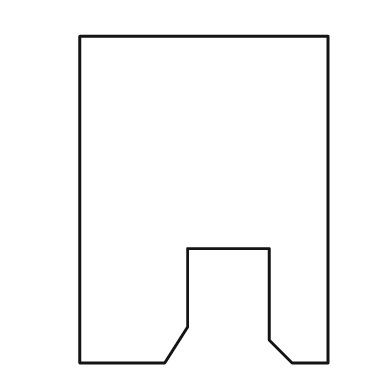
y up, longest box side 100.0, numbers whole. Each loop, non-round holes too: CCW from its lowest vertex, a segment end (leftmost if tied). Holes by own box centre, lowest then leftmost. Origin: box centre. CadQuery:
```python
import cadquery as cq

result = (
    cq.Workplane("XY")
    .moveTo(-38.0, -50.0)
    .lineTo(-12.0, -50.0)
    .lineTo(-5.0, -39.0)
    .lineTo(-5.0, -15.0)
    .lineTo(20.0, -15.0)
    .lineTo(20.0, -43.0)
    .lineTo(27.0, -50.0)
    .lineTo(38.0, -50.0)
    .lineTo(38.0, 50.0)
    .lineTo(-38.0, 50.0)
    .close()
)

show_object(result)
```